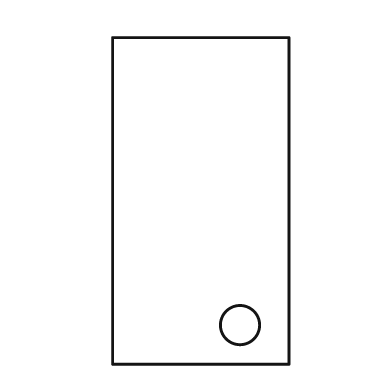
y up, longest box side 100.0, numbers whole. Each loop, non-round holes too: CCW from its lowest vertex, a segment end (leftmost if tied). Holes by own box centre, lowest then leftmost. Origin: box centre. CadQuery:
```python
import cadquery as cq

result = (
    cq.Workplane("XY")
    .moveTo(-27.0, -50.0)
    .lineTo(27.0, -50.0)
    .lineTo(27.0, 50.0)
    .lineTo(-27.0, 50.0)
    .close()
    .moveTo(12.0, -38.0)
    .circle(6.0)
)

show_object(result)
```